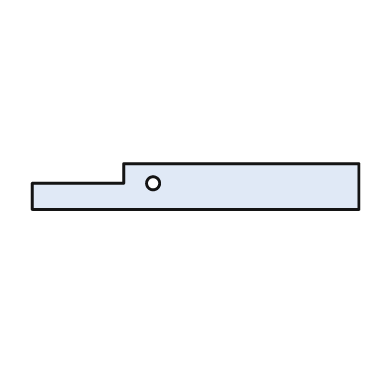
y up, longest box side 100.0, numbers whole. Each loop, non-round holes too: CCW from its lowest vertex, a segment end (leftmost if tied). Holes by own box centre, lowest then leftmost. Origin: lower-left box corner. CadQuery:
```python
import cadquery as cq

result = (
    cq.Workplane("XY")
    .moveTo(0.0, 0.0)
    .lineTo(100.0, 0.0)
    .lineTo(100.0, 14.0)
    .lineTo(28.0, 14.0)
    .lineTo(28.0, 8.0)
    .lineTo(0.0, 8.0)
    .close()
    .moveTo(37.0, 8.0)
    .circle(2.0)
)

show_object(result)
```